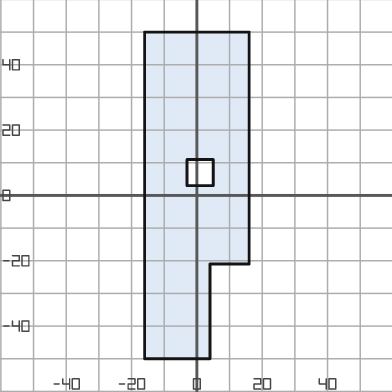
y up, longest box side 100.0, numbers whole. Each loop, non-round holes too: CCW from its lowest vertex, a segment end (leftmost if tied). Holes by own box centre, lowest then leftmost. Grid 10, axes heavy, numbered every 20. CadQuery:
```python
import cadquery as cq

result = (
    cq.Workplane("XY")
    .moveTo(-16.0, -50.0)
    .lineTo(4.0, -50.0)
    .lineTo(4.0, -21.0)
    .lineTo(16.0, -21.0)
    .lineTo(16.0, 50.0)
    .lineTo(-16.0, 50.0)
    .close()
    .moveTo(-3.0, 3.0)
    .lineTo(5.0, 3.0)
    .lineTo(5.0, 11.0)
    .lineTo(-3.0, 11.0)
    .close()
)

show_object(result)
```